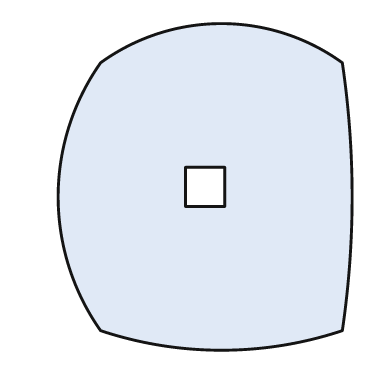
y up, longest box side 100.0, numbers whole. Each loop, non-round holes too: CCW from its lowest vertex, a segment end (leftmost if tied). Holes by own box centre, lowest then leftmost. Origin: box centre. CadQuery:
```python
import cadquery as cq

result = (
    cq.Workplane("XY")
    .moveTo(-32.0, -44.0)
    .threePointArc((5.0, -50.0), (42.0, -44.0))
    .threePointArc((45.0, -3.0), (42.0, 38.0))
    .threePointArc((5.0, 50.0), (-32.0, 38.0))
    .threePointArc((-45.0, -3.0), (-32.0, -44.0))
    .close()
    .moveTo(-6.0, -6.0)
    .lineTo(6.0, -6.0)
    .lineTo(6.0, 6.0)
    .lineTo(-6.0, 6.0)
    .close()
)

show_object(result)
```